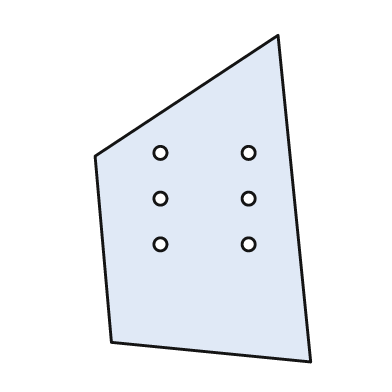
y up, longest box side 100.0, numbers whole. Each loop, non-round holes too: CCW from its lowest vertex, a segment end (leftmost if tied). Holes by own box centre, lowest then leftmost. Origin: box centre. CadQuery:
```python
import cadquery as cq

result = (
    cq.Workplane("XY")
    .moveTo(33.0, -50.0)
    .lineTo(23.0, 50.0)
    .lineTo(-33.0, 13.0)
    .lineTo(-28.0, -44.0)
    .close()
    .moveTo(-13.0, -14.0)
    .circle(2.0)
    .moveTo(14.0, -14.0)
    .circle(2.0)
    .moveTo(-13.0, 0.0)
    .circle(2.0)
    .moveTo(14.0, 0.0)
    .circle(2.0)
    .moveTo(-13.0, 14.0)
    .circle(2.0)
    .moveTo(14.0, 14.0)
    .circle(2.0)
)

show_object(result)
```